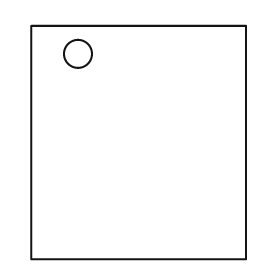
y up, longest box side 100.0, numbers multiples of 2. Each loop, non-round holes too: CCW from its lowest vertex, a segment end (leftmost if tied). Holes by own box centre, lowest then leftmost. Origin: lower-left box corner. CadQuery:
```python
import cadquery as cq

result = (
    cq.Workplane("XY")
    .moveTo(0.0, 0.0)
    .lineTo(92.0, 0.0)
    .lineTo(92.0, 100.0)
    .lineTo(0.0, 100.0)
    .close()
    .moveTo(20.0, 88.0)
    .circle(6.0)
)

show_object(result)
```